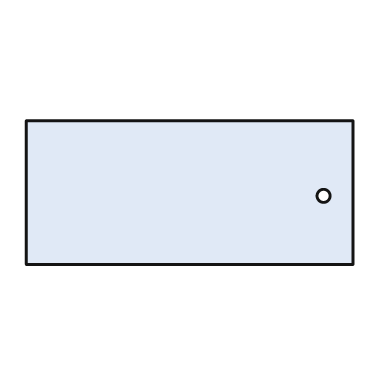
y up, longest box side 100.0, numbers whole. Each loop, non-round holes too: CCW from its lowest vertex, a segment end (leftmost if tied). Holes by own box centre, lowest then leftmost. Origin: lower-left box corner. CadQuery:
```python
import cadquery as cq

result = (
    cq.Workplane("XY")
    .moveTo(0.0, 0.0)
    .lineTo(100.0, 0.0)
    .lineTo(100.0, 44.0)
    .lineTo(0.0, 44.0)
    .close()
    .moveTo(91.0, 21.0)
    .circle(2.0)
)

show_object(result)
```